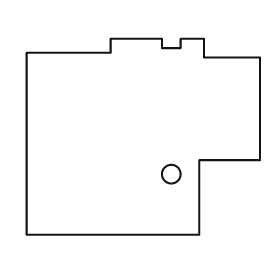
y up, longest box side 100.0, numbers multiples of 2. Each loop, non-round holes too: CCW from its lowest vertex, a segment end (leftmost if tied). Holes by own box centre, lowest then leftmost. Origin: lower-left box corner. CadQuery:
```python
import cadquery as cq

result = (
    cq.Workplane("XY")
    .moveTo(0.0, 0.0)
    .lineTo(74.0, 0.0)
    .lineTo(74.0, 32.0)
    .lineTo(100.0, 32.0)
    .lineTo(100.0, 76.0)
    .lineTo(76.0, 76.0)
    .lineTo(76.0, 84.0)
    .lineTo(66.0, 84.0)
    .lineTo(66.0, 80.0)
    .lineTo(58.0, 80.0)
    .lineTo(58.0, 84.0)
    .lineTo(36.0, 84.0)
    .lineTo(36.0, 78.0)
    .lineTo(0.0, 78.0)
    .close()
    .moveTo(62.0, 26.0)
    .circle(4.0)
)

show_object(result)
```